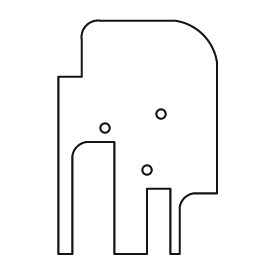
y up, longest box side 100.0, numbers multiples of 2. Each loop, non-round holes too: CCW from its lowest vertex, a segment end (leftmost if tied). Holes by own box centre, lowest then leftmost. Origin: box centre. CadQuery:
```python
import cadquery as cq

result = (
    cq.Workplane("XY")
    .moveTo(-34.0, -50.0)
    .lineTo(-28.0, -50.0)
    .lineTo(-28.0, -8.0)
    .threePointArc((-26.0, -4.0), (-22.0, -2.0))
    .lineTo(-10.0, -2.0)
    .lineTo(-10.0, -50.0)
    .lineTo(4.0, -50.0)
    .lineTo(4.0, -22.0)
    .lineTo(14.0, -22.0)
    .lineTo(14.0, -50.0)
    .lineTo(18.0, -50.0)
    .lineTo(18.0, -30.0)
    .threePointArc((20.0, -26.0), (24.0, -24.0))
    .lineTo(34.0, -24.0)
    .lineTo(34.0, 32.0)
    .threePointArc((28.0, 44.0), (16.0, 50.0))
    .lineTo(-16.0, 50.0)
    .threePointArc((-22.0, 48.0), (-24.0, 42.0))
    .lineTo(-24.0, 26.0)
    .lineTo(-34.0, 26.0)
    .close()
    .moveTo(4.0, -14.0)
    .circle(2.0)
    .moveTo(-14.0, 4.0)
    .circle(2.0)
    .moveTo(10.0, 10.0)
    .circle(2.0)
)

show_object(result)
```